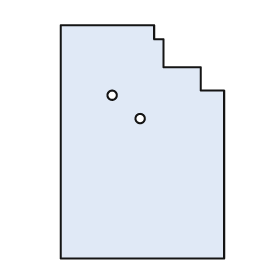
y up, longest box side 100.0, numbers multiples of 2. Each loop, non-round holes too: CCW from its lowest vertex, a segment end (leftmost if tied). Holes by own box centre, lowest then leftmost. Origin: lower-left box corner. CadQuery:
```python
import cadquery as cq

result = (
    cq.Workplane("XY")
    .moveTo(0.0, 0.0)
    .lineTo(70.0, 0.0)
    .lineTo(70.0, 72.0)
    .lineTo(60.0, 72.0)
    .lineTo(60.0, 82.0)
    .lineTo(44.0, 82.0)
    .lineTo(44.0, 94.0)
    .lineTo(40.0, 94.0)
    .lineTo(40.0, 100.0)
    .lineTo(0.0, 100.0)
    .close()
    .moveTo(34.0, 60.0)
    .circle(2.0)
    .moveTo(22.0, 70.0)
    .circle(2.0)
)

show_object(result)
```